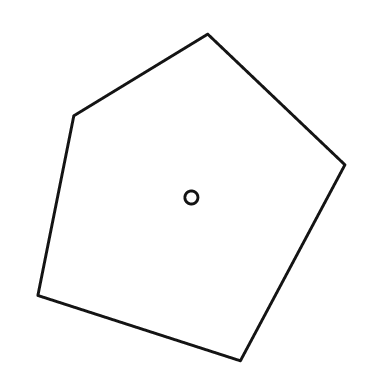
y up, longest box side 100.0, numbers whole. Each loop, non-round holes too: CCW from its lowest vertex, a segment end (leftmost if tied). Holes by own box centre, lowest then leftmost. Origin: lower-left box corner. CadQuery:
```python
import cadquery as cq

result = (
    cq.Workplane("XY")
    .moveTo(62.0, 0.0)
    .lineTo(94.0, 60.0)
    .lineTo(52.0, 100.0)
    .lineTo(11.0, 75.0)
    .lineTo(0.0, 20.0)
    .close()
    .moveTo(47.0, 50.0)
    .circle(2.0)
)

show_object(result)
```